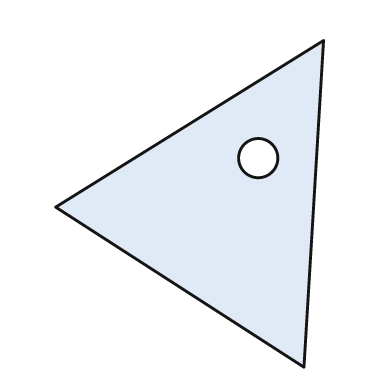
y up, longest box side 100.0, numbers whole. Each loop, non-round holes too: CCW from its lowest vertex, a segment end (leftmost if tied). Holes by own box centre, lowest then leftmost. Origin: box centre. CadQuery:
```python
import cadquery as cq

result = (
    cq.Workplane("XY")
    .moveTo(35.0, -50.0)
    .lineTo(41.0, 50.0)
    .lineTo(-41.0, -1.0)
    .close()
    .moveTo(21.0, 14.0)
    .circle(6.0)
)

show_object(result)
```